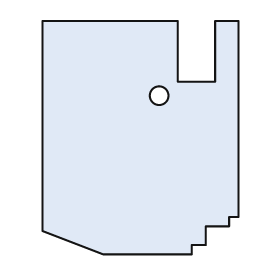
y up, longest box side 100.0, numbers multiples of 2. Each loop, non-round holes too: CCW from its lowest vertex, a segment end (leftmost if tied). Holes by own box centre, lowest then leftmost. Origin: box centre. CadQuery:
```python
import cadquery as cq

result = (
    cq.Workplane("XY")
    .moveTo(-16.0, -50.0)
    .lineTo(22.0, -50.0)
    .lineTo(22.0, -46.0)
    .lineTo(28.0, -46.0)
    .lineTo(28.0, -38.0)
    .lineTo(38.0, -38.0)
    .lineTo(38.0, -34.0)
    .lineTo(42.0, -34.0)
    .lineTo(42.0, 50.0)
    .lineTo(32.0, 50.0)
    .lineTo(32.0, 24.0)
    .lineTo(16.0, 24.0)
    .lineTo(16.0, 50.0)
    .lineTo(-42.0, 50.0)
    .lineTo(-42.0, -40.0)
    .close()
    .moveTo(8.0, 18.0)
    .circle(4.0)
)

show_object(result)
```